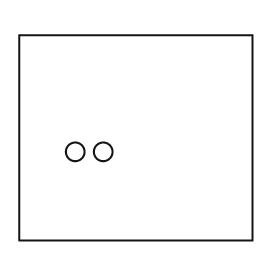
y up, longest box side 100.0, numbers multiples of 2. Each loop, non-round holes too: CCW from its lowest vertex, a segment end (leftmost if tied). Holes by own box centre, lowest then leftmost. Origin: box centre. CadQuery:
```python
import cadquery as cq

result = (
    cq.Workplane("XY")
    .moveTo(-50.0, -44.0)
    .lineTo(50.0, -44.0)
    .lineTo(50.0, 44.0)
    .lineTo(-50.0, 44.0)
    .close()
    .moveTo(-26.0, -6.0)
    .circle(4.0)
    .moveTo(-14.0, -6.0)
    .circle(4.0)
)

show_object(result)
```